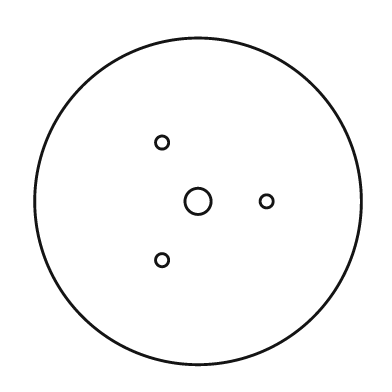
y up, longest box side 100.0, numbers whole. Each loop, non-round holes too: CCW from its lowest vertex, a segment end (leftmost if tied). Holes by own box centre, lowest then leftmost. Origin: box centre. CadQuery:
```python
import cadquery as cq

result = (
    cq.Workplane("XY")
    .moveTo(0.0, 0.0)
    .circle(50.0)
    .moveTo(-11.0, -18.0)
    .circle(2.0)
    .moveTo(0.0, 0.0)
    .circle(4.0)
    .moveTo(21.0, 0.0)
    .circle(2.0)
    .moveTo(-11.0, 18.0)
    .circle(2.0)
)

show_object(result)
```